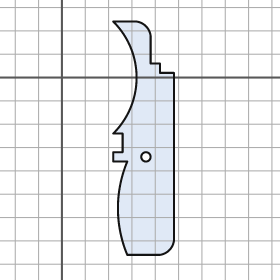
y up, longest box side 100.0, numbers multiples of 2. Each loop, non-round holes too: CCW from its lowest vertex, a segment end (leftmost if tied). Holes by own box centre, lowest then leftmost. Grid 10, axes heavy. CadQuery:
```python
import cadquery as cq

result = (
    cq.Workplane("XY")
    .moveTo(28.0, -76.0)
    .lineTo(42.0, -76.0)
    .threePointArc((46.0, -74.0), (48.0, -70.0))
    .lineTo(48.0, 2.0)
    .lineTo(42.0, 2.0)
    .lineTo(42.0, 6.0)
    .lineTo(38.0, 6.0)
    .lineTo(38.0, 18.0)
    .threePointArc((36.0, 22.0), (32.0, 24.0))
    .lineTo(22.0, 24.0)
    .threePointArc((32.0, 0.0), (22.0, -24.0))
    .lineTo(26.0, -24.0)
    .lineTo(26.0, -32.0)
    .lineTo(22.0, -32.0)
    .lineTo(22.0, -36.0)
    .lineTo(28.0, -36.0)
    .threePointArc((24.0, -56.0), (28.0, -76.0))
    .close()
    .moveTo(36.0, -34.0)
    .circle(2.0)
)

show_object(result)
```